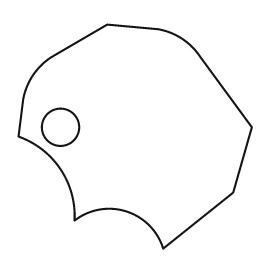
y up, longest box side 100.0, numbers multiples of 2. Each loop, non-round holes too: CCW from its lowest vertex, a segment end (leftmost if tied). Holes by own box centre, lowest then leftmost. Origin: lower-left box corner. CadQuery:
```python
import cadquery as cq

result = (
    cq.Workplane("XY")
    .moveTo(62.0, 0.0)
    .lineTo(92.0, 24.0)
    .lineTo(100.0, 52.0)
    .lineTo(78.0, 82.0)
    .threePointArc((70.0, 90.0), (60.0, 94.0))
    .lineTo(38.0, 96.0)
    .lineTo(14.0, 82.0)
    .threePointArc((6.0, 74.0), (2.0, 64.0))
    .lineTo(0.0, 48.0)
    .threePointArc((18.0, 34.0), (24.0, 12.0))
    .threePointArc((46.0, 16.0), (62.0, 0.0))
    .close()
    .moveTo(18.0, 52.0)
    .circle(8.0)
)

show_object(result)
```